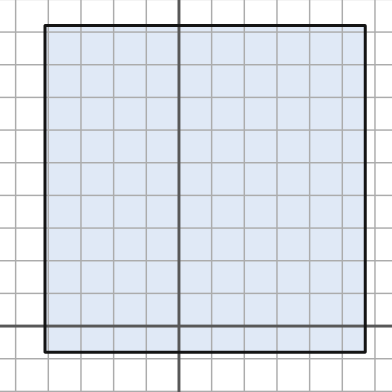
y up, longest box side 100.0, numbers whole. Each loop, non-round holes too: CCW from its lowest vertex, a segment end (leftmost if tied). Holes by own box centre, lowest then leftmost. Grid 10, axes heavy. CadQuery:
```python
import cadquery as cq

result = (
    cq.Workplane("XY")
    .moveTo(-41.0, -8.0)
    .lineTo(57.0, -8.0)
    .lineTo(57.0, 92.0)
    .lineTo(-41.0, 92.0)
    .close()
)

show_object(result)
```